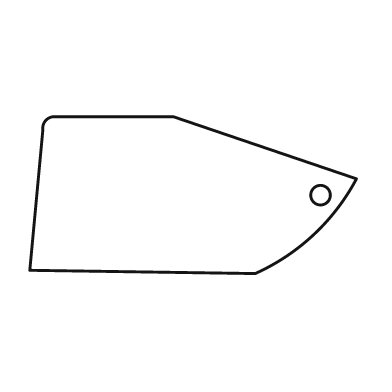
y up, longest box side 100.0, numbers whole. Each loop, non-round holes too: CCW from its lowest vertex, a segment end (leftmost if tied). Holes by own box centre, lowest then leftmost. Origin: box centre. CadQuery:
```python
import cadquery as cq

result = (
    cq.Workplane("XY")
    .moveTo(19.0, -24.0)
    .threePointArc((37.0, -12.0), (50.0, 5.0))
    .lineTo(-6.0, 24.0)
    .lineTo(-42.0, 24.0)
    .threePointArc((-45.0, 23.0), (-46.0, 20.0))
    .lineTo(-50.0, -23.0)
    .close()
    .moveTo(39.0, 0.0)
    .circle(3.0)
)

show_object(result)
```